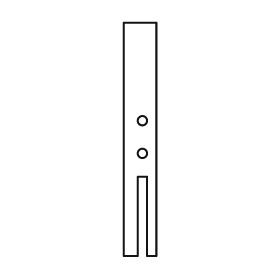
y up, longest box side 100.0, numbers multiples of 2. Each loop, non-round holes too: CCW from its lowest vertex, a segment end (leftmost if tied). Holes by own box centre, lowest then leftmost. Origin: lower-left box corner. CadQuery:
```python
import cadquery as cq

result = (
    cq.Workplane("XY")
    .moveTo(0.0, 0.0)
    .lineTo(6.0, 0.0)
    .lineTo(6.0, 34.0)
    .lineTo(10.0, 34.0)
    .lineTo(10.0, 0.0)
    .lineTo(14.0, 0.0)
    .lineTo(14.0, 100.0)
    .lineTo(0.0, 100.0)
    .close()
    .moveTo(8.0, 44.0)
    .circle(2.0)
    .moveTo(8.0, 58.0)
    .circle(2.0)
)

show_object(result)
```